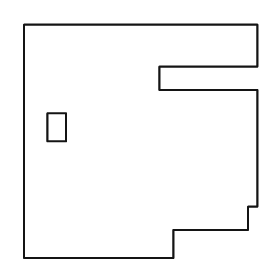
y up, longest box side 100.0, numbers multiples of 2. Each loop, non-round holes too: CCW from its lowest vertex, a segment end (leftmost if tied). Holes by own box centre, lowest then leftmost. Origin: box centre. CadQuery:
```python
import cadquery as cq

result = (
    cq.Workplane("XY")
    .moveTo(-50.0, -50.0)
    .lineTo(14.0, -50.0)
    .lineTo(14.0, -38.0)
    .lineTo(46.0, -38.0)
    .lineTo(46.0, -28.0)
    .lineTo(50.0, -28.0)
    .lineTo(50.0, 22.0)
    .lineTo(8.0, 22.0)
    .lineTo(8.0, 32.0)
    .lineTo(50.0, 32.0)
    .lineTo(50.0, 50.0)
    .lineTo(-50.0, 50.0)
    .close()
    .moveTo(-40.0, 0.0)
    .lineTo(-32.0, 0.0)
    .lineTo(-32.0, 12.0)
    .lineTo(-40.0, 12.0)
    .close()
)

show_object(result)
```